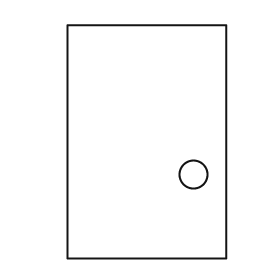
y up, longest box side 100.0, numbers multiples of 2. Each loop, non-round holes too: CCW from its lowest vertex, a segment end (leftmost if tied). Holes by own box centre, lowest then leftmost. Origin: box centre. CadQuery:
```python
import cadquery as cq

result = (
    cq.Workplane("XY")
    .moveTo(-34.0, -50.0)
    .lineTo(34.0, -50.0)
    .lineTo(34.0, 50.0)
    .lineTo(-34.0, 50.0)
    .close()
    .moveTo(20.0, -14.0)
    .circle(6.0)
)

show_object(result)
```